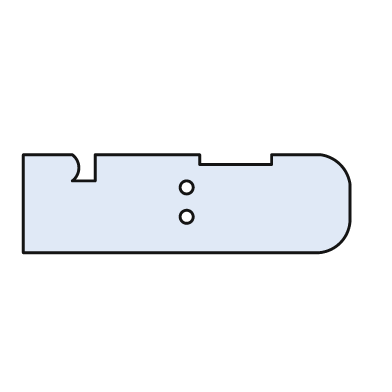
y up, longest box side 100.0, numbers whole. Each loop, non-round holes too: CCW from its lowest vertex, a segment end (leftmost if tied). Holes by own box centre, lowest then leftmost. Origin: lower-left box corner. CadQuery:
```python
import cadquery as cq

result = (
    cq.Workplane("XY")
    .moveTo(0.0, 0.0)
    .lineTo(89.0, 0.0)
    .threePointArc((97.0, 3.0), (100.0, 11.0))
    .lineTo(100.0, 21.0)
    .threePointArc((97.0, 27.0), (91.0, 30.0))
    .lineTo(76.0, 30.0)
    .lineTo(76.0, 27.0)
    .lineTo(54.0, 27.0)
    .lineTo(54.0, 30.0)
    .lineTo(22.0, 30.0)
    .lineTo(22.0, 22.0)
    .lineTo(15.0, 22.0)
    .threePointArc((17.0, 26.0), (15.0, 30.0))
    .lineTo(0.0, 30.0)
    .close()
    .moveTo(50.0, 11.0)
    .circle(2.0)
    .moveTo(50.0, 20.0)
    .circle(2.0)
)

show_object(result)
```